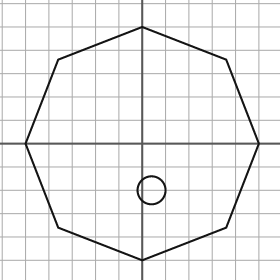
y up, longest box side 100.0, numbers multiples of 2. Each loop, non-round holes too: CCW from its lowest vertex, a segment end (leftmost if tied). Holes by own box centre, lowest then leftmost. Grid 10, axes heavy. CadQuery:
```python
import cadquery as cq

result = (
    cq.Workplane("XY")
    .moveTo(0.0, -50.0)
    .lineTo(36.0, -36.0)
    .lineTo(50.0, 0.0)
    .lineTo(36.0, 36.0)
    .lineTo(0.0, 50.0)
    .lineTo(-36.0, 36.0)
    .lineTo(-50.0, 0.0)
    .lineTo(-36.0, -36.0)
    .close()
    .moveTo(4.0, -20.0)
    .circle(6.0)
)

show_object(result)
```